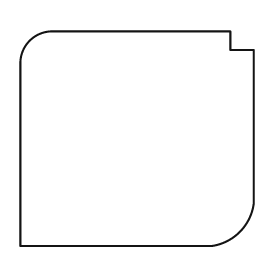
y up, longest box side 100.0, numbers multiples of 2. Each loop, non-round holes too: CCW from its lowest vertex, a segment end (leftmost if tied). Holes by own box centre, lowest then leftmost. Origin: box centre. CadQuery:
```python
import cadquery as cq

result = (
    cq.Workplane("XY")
    .moveTo(-50.0, -46.0)
    .lineTo(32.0, -46.0)
    .threePointArc((44.0, -40.0), (50.0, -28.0))
    .lineTo(50.0, 38.0)
    .lineTo(40.0, 38.0)
    .lineTo(40.0, 46.0)
    .lineTo(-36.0, 46.0)
    .threePointArc((-46.0, 42.0), (-50.0, 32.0))
    .close()
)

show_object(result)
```